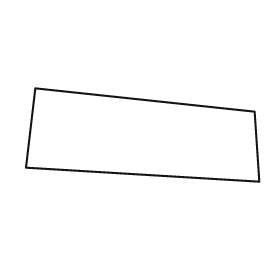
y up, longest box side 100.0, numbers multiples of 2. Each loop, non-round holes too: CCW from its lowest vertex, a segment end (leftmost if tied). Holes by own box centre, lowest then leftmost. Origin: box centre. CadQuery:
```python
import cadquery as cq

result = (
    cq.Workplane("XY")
    .moveTo(50.0, -20.0)
    .lineTo(48.0, 10.0)
    .lineTo(-46.0, 20.0)
    .lineTo(-50.0, -14.0)
    .close()
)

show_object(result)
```